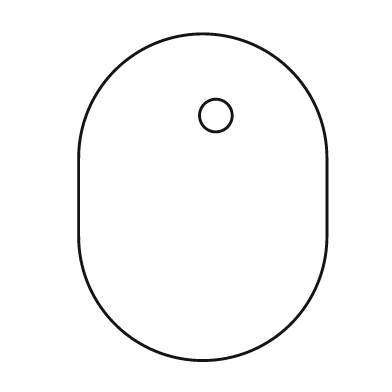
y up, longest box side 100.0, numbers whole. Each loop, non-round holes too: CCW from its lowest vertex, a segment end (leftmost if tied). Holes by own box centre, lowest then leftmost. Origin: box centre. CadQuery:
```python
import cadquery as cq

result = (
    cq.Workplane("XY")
    .moveTo(-38.0, -12.0)
    .threePointArc((0.0, -50.0), (38.0, -12.0))
    .lineTo(38.0, 12.0)
    .threePointArc((0.0, 50.0), (-38.0, 12.0))
    .close()
    .moveTo(4.0, 25.0)
    .circle(5.0)
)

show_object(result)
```